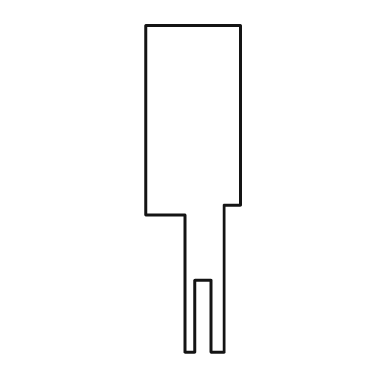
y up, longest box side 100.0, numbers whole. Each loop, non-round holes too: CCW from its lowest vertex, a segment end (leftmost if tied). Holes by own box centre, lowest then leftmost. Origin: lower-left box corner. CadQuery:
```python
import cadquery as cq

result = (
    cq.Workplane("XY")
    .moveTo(12.0, 0.0)
    .lineTo(15.0, 0.0)
    .lineTo(15.0, 22.0)
    .lineTo(20.0, 22.0)
    .lineTo(20.0, 0.0)
    .lineTo(24.0, 0.0)
    .lineTo(24.0, 45.0)
    .lineTo(29.0, 45.0)
    .lineTo(29.0, 100.0)
    .lineTo(0.0, 100.0)
    .lineTo(0.0, 42.0)
    .lineTo(12.0, 42.0)
    .close()
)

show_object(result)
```